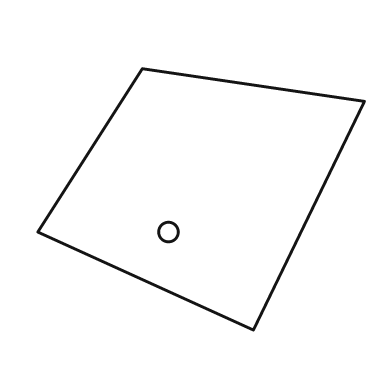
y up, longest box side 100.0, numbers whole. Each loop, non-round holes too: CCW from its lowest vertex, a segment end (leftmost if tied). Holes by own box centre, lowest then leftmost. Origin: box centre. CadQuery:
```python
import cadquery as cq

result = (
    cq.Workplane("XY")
    .moveTo(16.0, -40.0)
    .lineTo(50.0, 30.0)
    .lineTo(-18.0, 40.0)
    .lineTo(-50.0, -10.0)
    .close()
    .moveTo(-10.0, -10.0)
    .circle(3.0)
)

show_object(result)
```